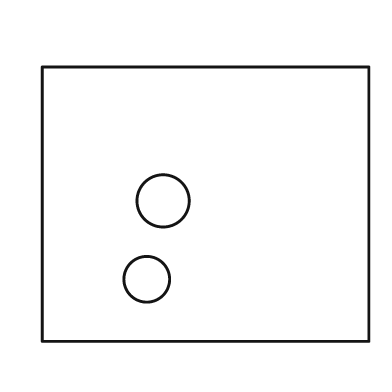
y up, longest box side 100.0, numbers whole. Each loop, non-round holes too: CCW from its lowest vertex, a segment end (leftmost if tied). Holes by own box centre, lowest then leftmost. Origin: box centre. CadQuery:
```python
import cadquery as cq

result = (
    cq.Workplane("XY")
    .moveTo(-50.0, -42.0)
    .lineTo(50.0, -42.0)
    .lineTo(50.0, 42.0)
    .lineTo(-50.0, 42.0)
    .close()
    .moveTo(-18.0, -23.0)
    .circle(7.0)
    .moveTo(-13.0, 1.0)
    .circle(8.0)
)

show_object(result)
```